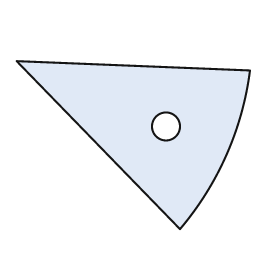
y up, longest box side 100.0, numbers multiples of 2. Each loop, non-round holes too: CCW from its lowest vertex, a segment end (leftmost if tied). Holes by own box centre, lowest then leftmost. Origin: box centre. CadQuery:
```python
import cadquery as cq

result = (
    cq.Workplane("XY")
    .moveTo(20.0, -36.0)
    .threePointArc((40.0, -4.0), (50.0, 32.0))
    .lineTo(-50.0, 36.0)
    .close()
    .moveTo(14.0, 8.0)
    .circle(6.0)
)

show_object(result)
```